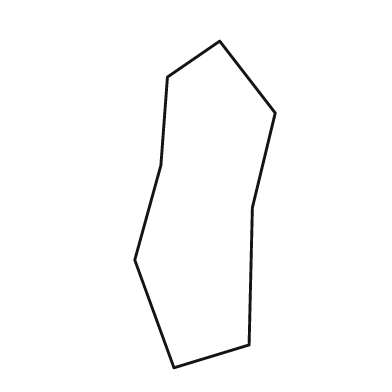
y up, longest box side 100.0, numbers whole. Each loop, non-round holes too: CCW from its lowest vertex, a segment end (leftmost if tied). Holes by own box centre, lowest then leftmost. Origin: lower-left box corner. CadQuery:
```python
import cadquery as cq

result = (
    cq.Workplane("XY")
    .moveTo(12.0, 0.0)
    .lineTo(35.0, 7.0)
    .lineTo(36.0, 49.0)
    .lineTo(43.0, 78.0)
    .lineTo(26.0, 100.0)
    .lineTo(10.0, 89.0)
    .lineTo(8.0, 62.0)
    .lineTo(0.0, 33.0)
    .close()
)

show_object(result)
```